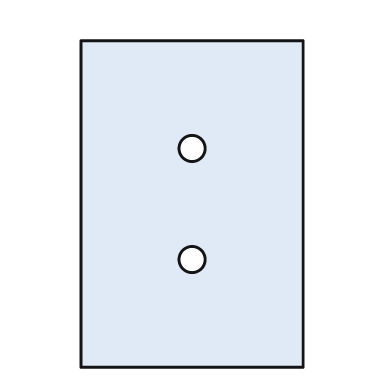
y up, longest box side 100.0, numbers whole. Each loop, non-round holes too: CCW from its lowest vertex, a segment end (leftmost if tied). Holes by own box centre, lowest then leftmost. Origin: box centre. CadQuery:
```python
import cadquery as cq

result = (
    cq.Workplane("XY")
    .moveTo(-34.0, -50.0)
    .lineTo(34.0, -50.0)
    .lineTo(34.0, 50.0)
    .lineTo(-34.0, 50.0)
    .close()
    .moveTo(0.0, -17.0)
    .circle(4.0)
    .moveTo(0.0, 17.0)
    .circle(4.0)
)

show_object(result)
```